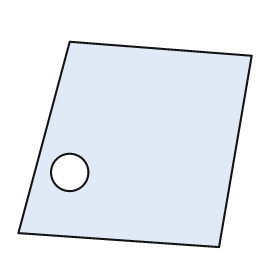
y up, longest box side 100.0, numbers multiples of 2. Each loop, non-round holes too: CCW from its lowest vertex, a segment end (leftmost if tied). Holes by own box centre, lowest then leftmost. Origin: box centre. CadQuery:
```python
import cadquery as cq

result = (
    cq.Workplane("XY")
    .moveTo(36.0, -44.0)
    .lineTo(50.0, 38.0)
    .lineTo(-28.0, 44.0)
    .lineTo(-50.0, -38.0)
    .close()
    .moveTo(-28.0, -12.0)
    .circle(8.0)
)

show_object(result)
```